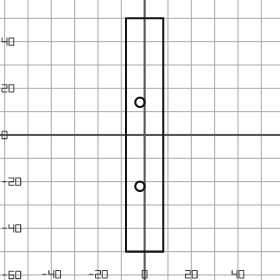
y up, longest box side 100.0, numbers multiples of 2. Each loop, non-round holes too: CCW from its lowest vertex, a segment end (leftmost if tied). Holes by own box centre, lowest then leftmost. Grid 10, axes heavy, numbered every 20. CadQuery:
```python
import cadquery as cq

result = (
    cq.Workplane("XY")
    .moveTo(-8.0, -50.0)
    .lineTo(8.0, -50.0)
    .lineTo(8.0, 50.0)
    .lineTo(-8.0, 50.0)
    .close()
    .moveTo(-2.0, -22.0)
    .circle(2.0)
    .moveTo(-2.0, 14.0)
    .circle(2.0)
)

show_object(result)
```